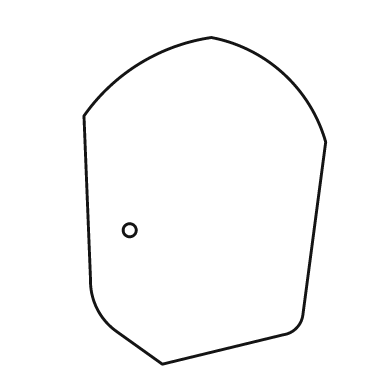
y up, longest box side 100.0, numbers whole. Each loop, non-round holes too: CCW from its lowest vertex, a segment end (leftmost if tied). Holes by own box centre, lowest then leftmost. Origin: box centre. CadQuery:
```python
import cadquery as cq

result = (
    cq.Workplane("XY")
    .moveTo(-13.0, -50.0)
    .lineTo(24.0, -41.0)
    .threePointArc((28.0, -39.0), (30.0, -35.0))
    .lineTo(37.0, 18.0)
    .threePointArc((24.0, 39.0), (2.0, 50.0))
    .threePointArc((-20.0, 42.0), (-37.0, 26.0))
    .lineTo(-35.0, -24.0)
    .threePointArc((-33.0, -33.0), (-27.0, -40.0))
    .close()
    .moveTo(-23.0, -9.0)
    .circle(2.0)
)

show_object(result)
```